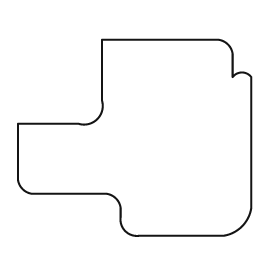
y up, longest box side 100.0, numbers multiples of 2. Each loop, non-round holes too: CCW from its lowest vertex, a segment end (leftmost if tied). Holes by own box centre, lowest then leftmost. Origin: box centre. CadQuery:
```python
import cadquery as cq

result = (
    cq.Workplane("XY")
    .moveTo(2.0, -42.0)
    .lineTo(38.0, -42.0)
    .threePointArc((46.0, -38.0), (50.0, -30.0))
    .lineTo(50.0, 26.0)
    .threePointArc((46.0, 28.0), (42.0, 26.0))
    .lineTo(42.0, 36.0)
    .threePointArc((40.0, 40.0), (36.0, 42.0))
    .lineTo(-14.0, 42.0)
    .lineTo(-14.0, 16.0)
    .threePointArc((-16.0, 8.0), (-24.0, 6.0))
    .lineTo(-50.0, 6.0)
    .lineTo(-50.0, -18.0)
    .threePointArc((-48.0, -22.0), (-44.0, -24.0))
    .lineTo(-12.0, -24.0)
    .threePointArc((-8.0, -26.0), (-6.0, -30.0))
    .lineTo(-6.0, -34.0)
    .threePointArc((-4.0, -40.0), (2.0, -42.0))
    .close()
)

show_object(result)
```